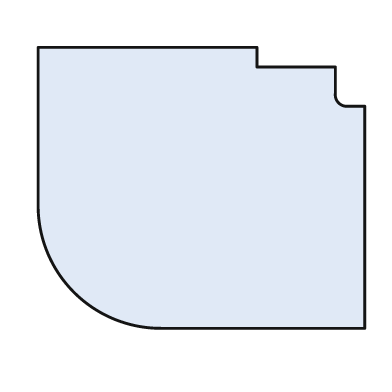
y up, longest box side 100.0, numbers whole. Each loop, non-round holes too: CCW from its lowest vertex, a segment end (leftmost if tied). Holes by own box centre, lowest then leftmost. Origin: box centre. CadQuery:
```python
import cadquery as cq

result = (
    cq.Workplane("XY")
    .moveTo(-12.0, -43.0)
    .lineTo(50.0, -43.0)
    .lineTo(50.0, 25.0)
    .lineTo(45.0, 25.0)
    .threePointArc((42.0, 26.0), (41.0, 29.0))
    .lineTo(41.0, 37.0)
    .lineTo(17.0, 37.0)
    .lineTo(17.0, 43.0)
    .lineTo(-50.0, 43.0)
    .lineTo(-50.0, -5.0)
    .threePointArc((-39.0, -32.0), (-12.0, -43.0))
    .close()
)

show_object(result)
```